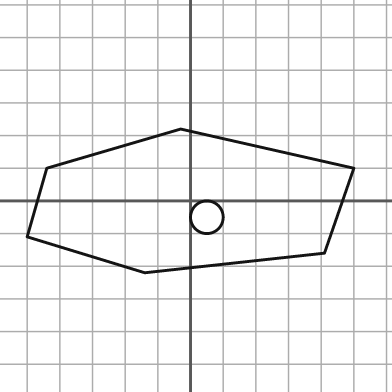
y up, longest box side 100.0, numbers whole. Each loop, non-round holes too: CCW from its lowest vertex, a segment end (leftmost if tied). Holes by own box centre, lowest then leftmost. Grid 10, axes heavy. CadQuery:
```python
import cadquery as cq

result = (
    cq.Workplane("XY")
    .moveTo(-14.0, -22.0)
    .lineTo(41.0, -16.0)
    .lineTo(50.0, 10.0)
    .lineTo(-3.0, 22.0)
    .lineTo(-44.0, 10.0)
    .lineTo(-50.0, -11.0)
    .close()
    .moveTo(5.0, -5.0)
    .circle(5.0)
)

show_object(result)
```